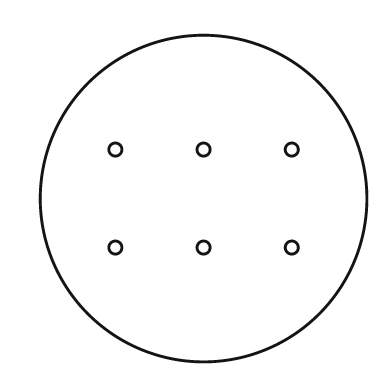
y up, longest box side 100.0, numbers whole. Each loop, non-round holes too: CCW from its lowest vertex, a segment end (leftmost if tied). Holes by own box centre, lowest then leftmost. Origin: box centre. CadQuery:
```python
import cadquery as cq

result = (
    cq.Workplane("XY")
    .moveTo(0.0, 0.0)
    .circle(50.0)
    .moveTo(-27.0, -15.0)
    .circle(2.0)
    .moveTo(0.0, -15.0)
    .circle(2.0)
    .moveTo(27.0, -15.0)
    .circle(2.0)
    .moveTo(-27.0, 15.0)
    .circle(2.0)
    .moveTo(0.0, 15.0)
    .circle(2.0)
    .moveTo(27.0, 15.0)
    .circle(2.0)
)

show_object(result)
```